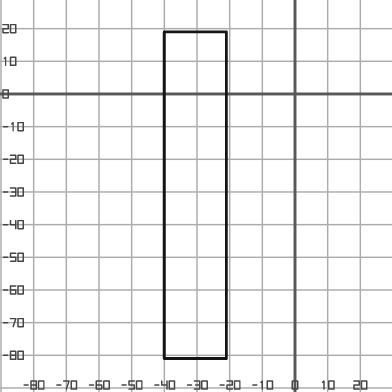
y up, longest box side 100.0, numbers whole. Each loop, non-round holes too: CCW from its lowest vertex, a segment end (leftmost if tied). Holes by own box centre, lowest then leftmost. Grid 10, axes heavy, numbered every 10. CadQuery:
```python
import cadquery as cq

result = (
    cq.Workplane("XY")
    .moveTo(-40.0, -81.0)
    .lineTo(-21.0, -81.0)
    .lineTo(-21.0, 19.0)
    .lineTo(-40.0, 19.0)
    .close()
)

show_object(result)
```